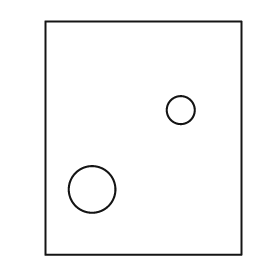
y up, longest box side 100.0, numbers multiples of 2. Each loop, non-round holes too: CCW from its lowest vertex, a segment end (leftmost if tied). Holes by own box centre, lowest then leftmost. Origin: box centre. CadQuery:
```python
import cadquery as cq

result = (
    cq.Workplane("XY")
    .moveTo(-42.0, -50.0)
    .lineTo(42.0, -50.0)
    .lineTo(42.0, 50.0)
    .lineTo(-42.0, 50.0)
    .close()
    .moveTo(-22.0, -22.0)
    .circle(10.0)
    .moveTo(16.0, 12.0)
    .circle(6.0)
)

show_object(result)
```